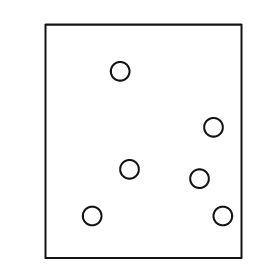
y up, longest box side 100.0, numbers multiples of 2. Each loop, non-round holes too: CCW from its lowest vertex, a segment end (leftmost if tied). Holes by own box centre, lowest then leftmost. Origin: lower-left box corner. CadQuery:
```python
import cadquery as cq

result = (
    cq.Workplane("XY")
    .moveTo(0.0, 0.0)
    .lineTo(84.0, 0.0)
    .lineTo(84.0, 100.0)
    .lineTo(0.0, 100.0)
    .close()
    .moveTo(20.0, 18.0)
    .circle(4.0)
    .moveTo(76.0, 18.0)
    .circle(4.0)
    .moveTo(66.0, 34.0)
    .circle(4.0)
    .moveTo(36.0, 38.0)
    .circle(4.0)
    .moveTo(72.0, 56.0)
    .circle(4.0)
    .moveTo(32.0, 80.0)
    .circle(4.0)
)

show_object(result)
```